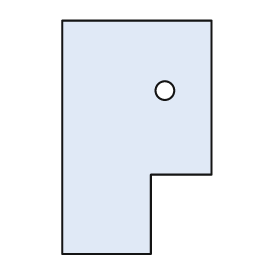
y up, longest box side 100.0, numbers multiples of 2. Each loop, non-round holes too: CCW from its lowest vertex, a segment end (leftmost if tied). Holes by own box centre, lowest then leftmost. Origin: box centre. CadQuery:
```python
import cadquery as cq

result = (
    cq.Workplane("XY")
    .moveTo(-32.0, -50.0)
    .lineTo(6.0, -50.0)
    .lineTo(6.0, -16.0)
    .lineTo(32.0, -16.0)
    .lineTo(32.0, 50.0)
    .lineTo(-32.0, 50.0)
    .close()
    .moveTo(12.0, 20.0)
    .circle(4.0)
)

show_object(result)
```